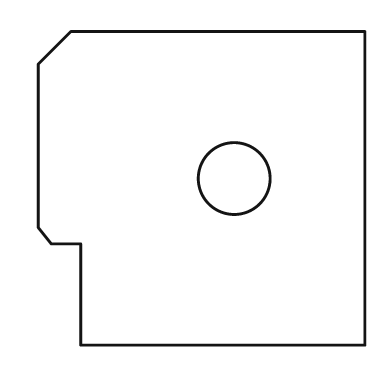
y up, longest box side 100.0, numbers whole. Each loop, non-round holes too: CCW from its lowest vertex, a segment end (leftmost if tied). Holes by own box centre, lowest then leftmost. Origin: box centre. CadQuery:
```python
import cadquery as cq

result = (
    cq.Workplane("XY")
    .moveTo(-37.0, -48.0)
    .lineTo(50.0, -48.0)
    .lineTo(50.0, 48.0)
    .lineTo(-40.0, 48.0)
    .lineTo(-50.0, 38.0)
    .lineTo(-50.0, -12.0)
    .lineTo(-46.0, -17.0)
    .lineTo(-37.0, -17.0)
    .close()
    .moveTo(10.0, 3.0)
    .circle(11.0)
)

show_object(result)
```